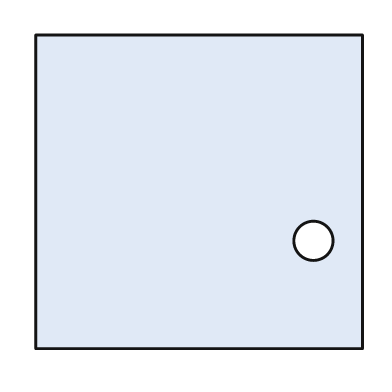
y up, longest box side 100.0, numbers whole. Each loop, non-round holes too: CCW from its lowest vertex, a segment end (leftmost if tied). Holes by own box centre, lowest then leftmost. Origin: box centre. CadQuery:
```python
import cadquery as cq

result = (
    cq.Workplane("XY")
    .moveTo(-50.0, -48.0)
    .lineTo(50.0, -48.0)
    .lineTo(50.0, 48.0)
    .lineTo(-50.0, 48.0)
    .close()
    .moveTo(35.0, -15.0)
    .circle(6.0)
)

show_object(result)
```